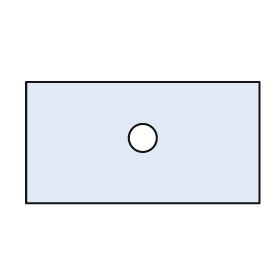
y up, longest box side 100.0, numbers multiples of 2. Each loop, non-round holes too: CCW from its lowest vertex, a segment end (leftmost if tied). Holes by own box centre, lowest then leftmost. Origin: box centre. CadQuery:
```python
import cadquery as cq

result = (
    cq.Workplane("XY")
    .moveTo(-50.0, -26.0)
    .lineTo(50.0, -26.0)
    .lineTo(50.0, 26.0)
    .lineTo(-50.0, 26.0)
    .close()
    .moveTo(0.0, 2.0)
    .circle(6.0)
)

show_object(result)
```